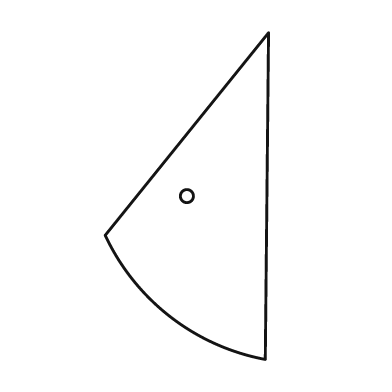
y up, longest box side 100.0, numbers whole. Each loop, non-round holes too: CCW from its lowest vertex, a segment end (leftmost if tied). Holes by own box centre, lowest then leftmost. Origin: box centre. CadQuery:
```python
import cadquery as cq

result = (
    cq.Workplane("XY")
    .moveTo(24.0, -50.0)
    .lineTo(25.0, 50.0)
    .lineTo(-25.0, -12.0)
    .threePointArc((-5.0, -37.0), (24.0, -50.0))
    .close()
    .moveTo(0.0, 0.0)
    .circle(2.0)
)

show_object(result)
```